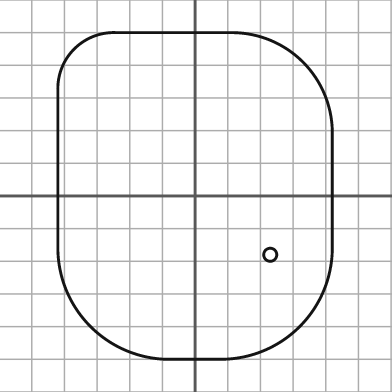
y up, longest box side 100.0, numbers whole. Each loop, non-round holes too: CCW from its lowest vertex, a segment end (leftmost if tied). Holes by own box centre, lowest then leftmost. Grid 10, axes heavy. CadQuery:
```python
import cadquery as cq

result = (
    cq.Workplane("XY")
    .moveTo(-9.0, -50.0)
    .lineTo(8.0, -50.0)
    .threePointArc((32.0, -40.0), (42.0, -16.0))
    .lineTo(42.0, 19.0)
    .threePointArc((33.0, 41.0), (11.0, 50.0))
    .lineTo(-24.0, 50.0)
    .threePointArc((-37.0, 45.0), (-42.0, 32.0))
    .lineTo(-42.0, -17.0)
    .threePointArc((-32.0, -40.0), (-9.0, -50.0))
    .close()
    .moveTo(23.0, -18.0)
    .circle(2.0)
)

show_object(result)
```